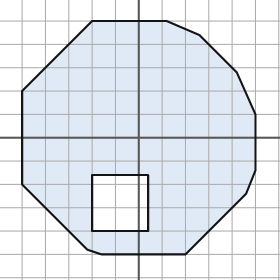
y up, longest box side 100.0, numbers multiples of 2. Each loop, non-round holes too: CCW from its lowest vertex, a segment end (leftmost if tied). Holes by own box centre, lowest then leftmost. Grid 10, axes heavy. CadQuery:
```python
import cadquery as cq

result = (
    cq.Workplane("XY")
    .moveTo(-16.0, -50.0)
    .lineTo(20.0, -50.0)
    .lineTo(46.0, -24.0)
    .lineTo(50.0, -14.0)
    .lineTo(50.0, 10.0)
    .lineTo(42.0, 28.0)
    .lineTo(26.0, 44.0)
    .lineTo(12.0, 50.0)
    .lineTo(-20.0, 50.0)
    .lineTo(-50.0, 20.0)
    .lineTo(-50.0, -20.0)
    .lineTo(-22.0, -48.0)
    .close()
    .moveTo(-20.0, -40.0)
    .lineTo(4.0, -40.0)
    .lineTo(4.0, -16.0)
    .lineTo(-20.0, -16.0)
    .close()
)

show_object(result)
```